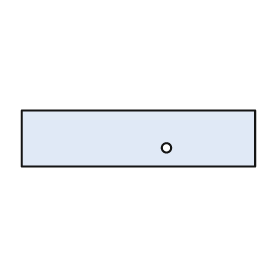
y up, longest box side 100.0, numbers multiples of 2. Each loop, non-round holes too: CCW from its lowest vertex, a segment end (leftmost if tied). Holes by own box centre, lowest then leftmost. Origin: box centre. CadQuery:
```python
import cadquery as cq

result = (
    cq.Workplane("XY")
    .moveTo(-50.0, -12.0)
    .lineTo(50.0, -12.0)
    .lineTo(50.0, 12.0)
    .lineTo(-50.0, 12.0)
    .close()
    .moveTo(12.0, -4.0)
    .circle(2.0)
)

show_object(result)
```